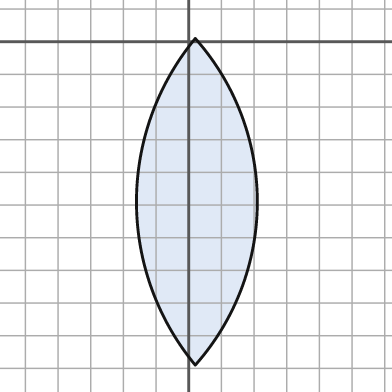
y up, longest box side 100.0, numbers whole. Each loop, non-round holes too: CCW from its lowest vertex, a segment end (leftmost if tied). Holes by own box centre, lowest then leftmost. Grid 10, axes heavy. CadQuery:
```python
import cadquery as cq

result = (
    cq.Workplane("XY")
    .moveTo(2.0, -99.0)
    .threePointArc((21.0, -49.0), (2.0, 1.0))
    .threePointArc((-16.0, -49.0), (2.0, -99.0))
    .close()
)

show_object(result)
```